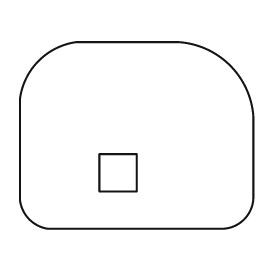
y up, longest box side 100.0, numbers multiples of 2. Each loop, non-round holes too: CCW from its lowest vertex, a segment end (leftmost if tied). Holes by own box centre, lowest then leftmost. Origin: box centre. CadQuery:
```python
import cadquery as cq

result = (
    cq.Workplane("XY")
    .moveTo(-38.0, -40.0)
    .lineTo(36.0, -40.0)
    .threePointArc((46.0, -36.0), (50.0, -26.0))
    .lineTo(50.0, 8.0)
    .threePointArc((40.0, 30.0), (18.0, 40.0))
    .lineTo(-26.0, 40.0)
    .threePointArc((-42.0, 32.0), (-50.0, 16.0))
    .lineTo(-50.0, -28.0)
    .threePointArc((-46.0, -36.0), (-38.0, -40.0))
    .close()
    .moveTo(-16.0, -24.0)
    .lineTo(0.0, -24.0)
    .lineTo(0.0, -8.0)
    .lineTo(-16.0, -8.0)
    .close()
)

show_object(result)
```